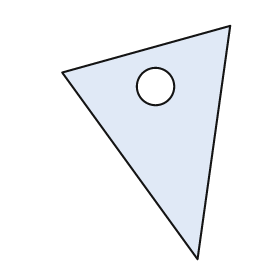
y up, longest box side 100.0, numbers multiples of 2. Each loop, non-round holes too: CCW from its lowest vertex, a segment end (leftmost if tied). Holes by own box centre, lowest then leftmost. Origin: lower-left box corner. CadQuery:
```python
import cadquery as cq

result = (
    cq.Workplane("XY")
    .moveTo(58.0, 0.0)
    .lineTo(72.0, 100.0)
    .lineTo(0.0, 80.0)
    .close()
    .moveTo(40.0, 74.0)
    .circle(8.0)
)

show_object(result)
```